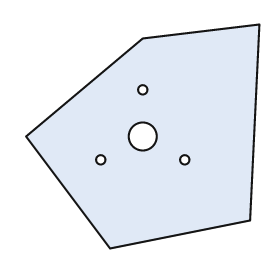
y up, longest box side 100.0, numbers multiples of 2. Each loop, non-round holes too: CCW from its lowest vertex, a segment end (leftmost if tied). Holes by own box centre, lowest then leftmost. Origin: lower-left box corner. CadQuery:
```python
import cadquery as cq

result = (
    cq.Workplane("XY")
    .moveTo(36.0, 0.0)
    .lineTo(96.0, 12.0)
    .lineTo(100.0, 96.0)
    .lineTo(50.0, 90.0)
    .lineTo(0.0, 48.0)
    .close()
    .moveTo(32.0, 38.0)
    .circle(2.0)
    .moveTo(68.0, 38.0)
    .circle(2.0)
    .moveTo(50.0, 48.0)
    .circle(6.0)
    .moveTo(50.0, 68.0)
    .circle(2.0)
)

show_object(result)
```